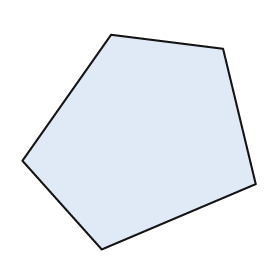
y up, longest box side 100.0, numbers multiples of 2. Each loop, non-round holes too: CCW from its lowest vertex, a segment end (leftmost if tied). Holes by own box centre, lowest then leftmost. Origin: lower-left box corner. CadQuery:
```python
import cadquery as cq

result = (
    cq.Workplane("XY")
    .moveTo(34.0, 0.0)
    .lineTo(100.0, 28.0)
    .lineTo(86.0, 86.0)
    .lineTo(38.0, 92.0)
    .lineTo(0.0, 38.0)
    .close()
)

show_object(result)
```